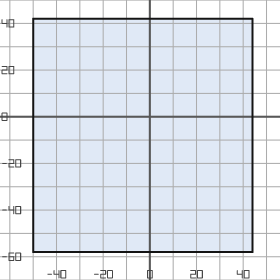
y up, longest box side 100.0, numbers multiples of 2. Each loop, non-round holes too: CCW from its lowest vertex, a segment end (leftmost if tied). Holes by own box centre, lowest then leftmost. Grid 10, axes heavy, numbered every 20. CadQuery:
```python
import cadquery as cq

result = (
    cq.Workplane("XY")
    .moveTo(-50.0, -58.0)
    .lineTo(44.0, -58.0)
    .lineTo(44.0, 42.0)
    .lineTo(-50.0, 42.0)
    .close()
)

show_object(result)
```